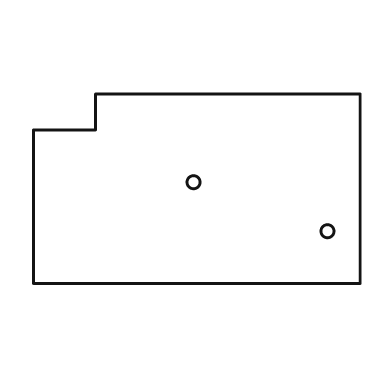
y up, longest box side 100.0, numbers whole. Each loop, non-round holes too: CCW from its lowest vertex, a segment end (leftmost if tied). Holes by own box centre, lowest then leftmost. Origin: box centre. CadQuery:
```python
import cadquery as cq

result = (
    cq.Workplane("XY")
    .moveTo(-50.0, -29.0)
    .lineTo(50.0, -29.0)
    .lineTo(50.0, 29.0)
    .lineTo(-31.0, 29.0)
    .lineTo(-31.0, 18.0)
    .lineTo(-50.0, 18.0)
    .close()
    .moveTo(40.0, -13.0)
    .circle(2.0)
    .moveTo(-1.0, 2.0)
    .circle(2.0)
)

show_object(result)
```